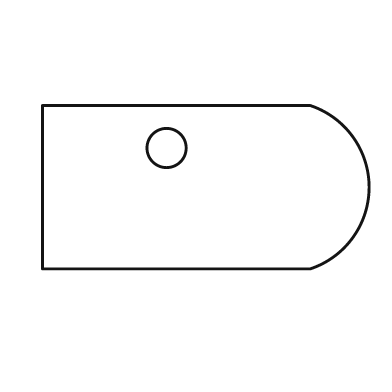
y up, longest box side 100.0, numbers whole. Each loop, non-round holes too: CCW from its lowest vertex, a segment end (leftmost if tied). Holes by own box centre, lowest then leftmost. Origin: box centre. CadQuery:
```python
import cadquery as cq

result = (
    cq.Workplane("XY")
    .moveTo(-50.0, -25.0)
    .lineTo(32.0, -25.0)
    .threePointArc((50.0, 0.0), (32.0, 25.0))
    .lineTo(-50.0, 25.0)
    .close()
    .moveTo(-12.0, 12.0)
    .circle(6.0)
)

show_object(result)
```